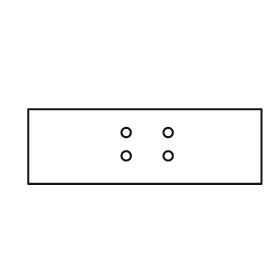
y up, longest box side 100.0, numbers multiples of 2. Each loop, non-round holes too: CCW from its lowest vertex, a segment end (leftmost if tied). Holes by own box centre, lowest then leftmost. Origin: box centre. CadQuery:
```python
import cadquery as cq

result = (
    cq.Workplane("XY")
    .moveTo(-50.0, -16.0)
    .lineTo(50.0, -16.0)
    .lineTo(50.0, 16.0)
    .lineTo(-50.0, 16.0)
    .close()
    .moveTo(-8.0, -4.0)
    .circle(2.0)
    .moveTo(10.0, -4.0)
    .circle(2.0)
    .moveTo(-8.0, 6.0)
    .circle(2.0)
    .moveTo(10.0, 6.0)
    .circle(2.0)
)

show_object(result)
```